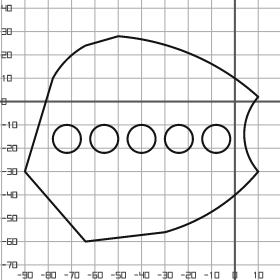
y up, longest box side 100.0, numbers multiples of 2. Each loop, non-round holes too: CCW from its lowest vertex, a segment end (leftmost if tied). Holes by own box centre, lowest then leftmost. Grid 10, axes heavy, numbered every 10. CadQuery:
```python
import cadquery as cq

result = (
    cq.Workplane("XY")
    .moveTo(-64.0, -60.0)
    .lineTo(-30.0, -56.0)
    .threePointArc((-8.0, -46.0), (10.0, -30.0))
    .threePointArc((4.0, -14.0), (10.0, 2.0))
    .threePointArc((-18.0, 20.0), (-50.0, 28.0))
    .lineTo(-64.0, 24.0)
    .threePointArc((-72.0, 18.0), (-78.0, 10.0))
    .lineTo(-90.0, -30.0)
    .close()
    .moveTo(-72.0, -16.0)
    .circle(6.0)
    .moveTo(-56.0, -16.0)
    .circle(6.0)
    .moveTo(-40.0, -16.0)
    .circle(6.0)
    .moveTo(-24.0, -16.0)
    .circle(6.0)
    .moveTo(-8.0, -16.0)
    .circle(6.0)
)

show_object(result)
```